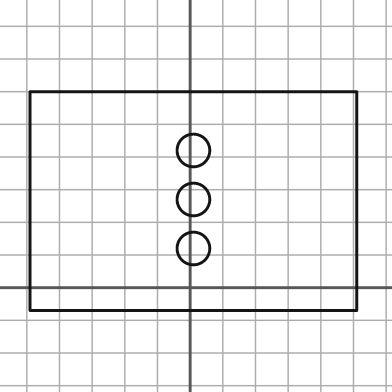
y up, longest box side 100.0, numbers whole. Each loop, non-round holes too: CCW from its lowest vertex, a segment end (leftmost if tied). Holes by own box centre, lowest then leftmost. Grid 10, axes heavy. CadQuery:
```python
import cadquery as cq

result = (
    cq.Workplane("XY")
    .moveTo(-49.0, -7.0)
    .lineTo(51.0, -7.0)
    .lineTo(51.0, 60.0)
    .lineTo(-49.0, 60.0)
    .close()
    .moveTo(1.0, 12.0)
    .circle(5.0)
    .moveTo(1.0, 27.0)
    .circle(5.0)
    .moveTo(1.0, 42.0)
    .circle(5.0)
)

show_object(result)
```